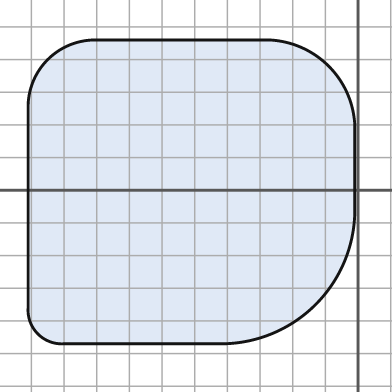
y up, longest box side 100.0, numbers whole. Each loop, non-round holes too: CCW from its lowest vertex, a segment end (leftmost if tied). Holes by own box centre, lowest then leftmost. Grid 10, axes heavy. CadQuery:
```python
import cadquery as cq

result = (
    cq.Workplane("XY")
    .moveTo(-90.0, -47.0)
    .lineTo(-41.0, -47.0)
    .threePointArc((-13.0, -35.0), (-1.0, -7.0))
    .lineTo(-1.0, 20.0)
    .threePointArc((-9.0, 38.0), (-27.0, 46.0))
    .lineTo(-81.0, 46.0)
    .threePointArc((-95.0, 40.0), (-101.0, 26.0))
    .lineTo(-101.0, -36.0)
    .threePointArc((-98.0, -44.0), (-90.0, -47.0))
    .close()
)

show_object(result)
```